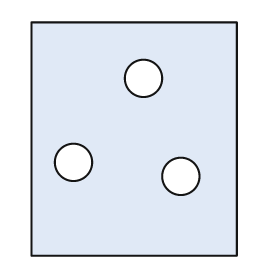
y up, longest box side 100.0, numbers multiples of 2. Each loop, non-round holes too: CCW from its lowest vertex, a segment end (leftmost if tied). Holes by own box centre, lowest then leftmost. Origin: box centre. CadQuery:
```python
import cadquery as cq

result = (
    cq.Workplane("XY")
    .moveTo(-44.0, -50.0)
    .lineTo(44.0, -50.0)
    .lineTo(44.0, 50.0)
    .lineTo(-44.0, 50.0)
    .close()
    .moveTo(20.0, -16.0)
    .circle(8.0)
    .moveTo(-26.0, -10.0)
    .circle(8.0)
    .moveTo(4.0, 26.0)
    .circle(8.0)
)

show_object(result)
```